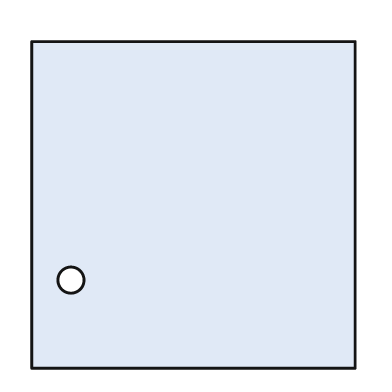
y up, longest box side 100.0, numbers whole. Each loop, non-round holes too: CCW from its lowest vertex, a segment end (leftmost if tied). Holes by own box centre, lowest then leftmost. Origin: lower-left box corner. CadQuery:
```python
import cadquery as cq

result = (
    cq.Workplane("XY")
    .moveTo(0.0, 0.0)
    .lineTo(99.0, 0.0)
    .lineTo(99.0, 100.0)
    .lineTo(0.0, 100.0)
    .close()
    .moveTo(12.0, 27.0)
    .circle(4.0)
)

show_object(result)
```